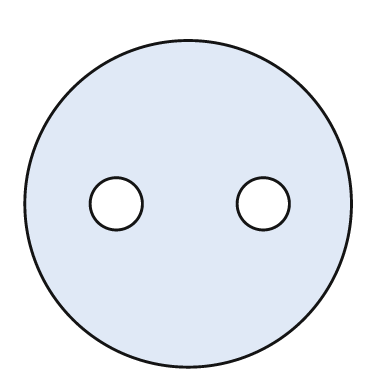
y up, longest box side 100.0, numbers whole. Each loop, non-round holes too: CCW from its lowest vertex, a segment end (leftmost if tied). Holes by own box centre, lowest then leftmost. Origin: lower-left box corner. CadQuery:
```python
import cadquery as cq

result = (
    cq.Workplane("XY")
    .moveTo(50.0, 50.0)
    .circle(50.0)
    .moveTo(28.0, 50.0)
    .circle(8.0)
    .moveTo(73.0, 50.0)
    .circle(8.0)
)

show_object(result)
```